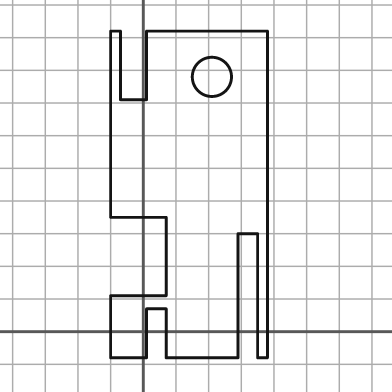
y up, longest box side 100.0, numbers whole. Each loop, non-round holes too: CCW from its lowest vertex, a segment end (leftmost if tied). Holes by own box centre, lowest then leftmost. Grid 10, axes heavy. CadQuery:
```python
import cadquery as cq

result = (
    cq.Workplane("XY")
    .moveTo(-10.0, -8.0)
    .lineTo(1.0, -8.0)
    .lineTo(1.0, 7.0)
    .lineTo(7.0, 7.0)
    .lineTo(7.0, -8.0)
    .lineTo(29.0, -8.0)
    .lineTo(29.0, 30.0)
    .lineTo(35.0, 30.0)
    .lineTo(35.0, -8.0)
    .lineTo(38.0, -8.0)
    .lineTo(38.0, 92.0)
    .lineTo(1.0, 92.0)
    .lineTo(1.0, 71.0)
    .lineTo(-7.0, 71.0)
    .lineTo(-7.0, 92.0)
    .lineTo(-10.0, 92.0)
    .lineTo(-10.0, 35.0)
    .lineTo(7.0, 35.0)
    .lineTo(7.0, 11.0)
    .lineTo(-10.0, 11.0)
    .close()
    .moveTo(21.0, 78.0)
    .circle(6.0)
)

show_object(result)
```